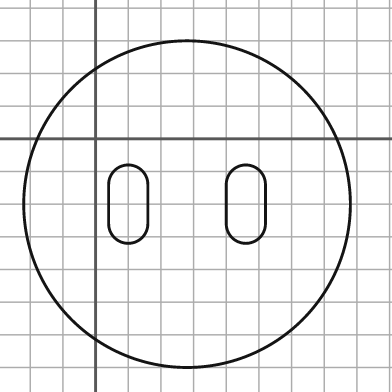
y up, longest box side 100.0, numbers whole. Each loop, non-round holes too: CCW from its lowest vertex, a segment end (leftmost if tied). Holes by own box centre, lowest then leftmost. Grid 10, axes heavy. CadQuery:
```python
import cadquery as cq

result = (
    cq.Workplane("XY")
    .moveTo(28.0, -20.0)
    .circle(50.0)
    .moveTo(4.0, -26.0)
    .threePointArc((10.0, -32.0), (16.0, -26.0))
    .lineTo(16.0, -14.0)
    .threePointArc((10.0, -8.0), (4.0, -14.0))
    .close()
    .moveTo(40.0, -26.0)
    .threePointArc((46.0, -32.0), (52.0, -26.0))
    .lineTo(52.0, -14.0)
    .threePointArc((46.0, -8.0), (40.0, -14.0))
    .close()
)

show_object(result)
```